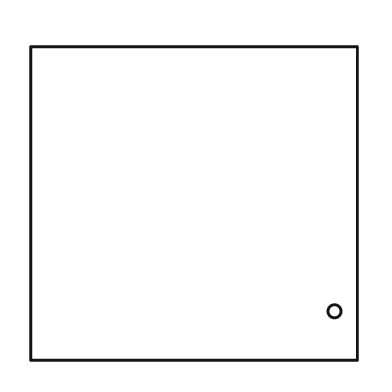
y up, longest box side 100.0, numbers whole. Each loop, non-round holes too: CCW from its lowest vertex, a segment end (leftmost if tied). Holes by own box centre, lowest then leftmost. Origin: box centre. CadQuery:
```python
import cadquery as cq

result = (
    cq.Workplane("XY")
    .moveTo(-50.0, -48.0)
    .lineTo(50.0, -48.0)
    .lineTo(50.0, 48.0)
    .lineTo(-50.0, 48.0)
    .close()
    .moveTo(43.0, -33.0)
    .circle(2.0)
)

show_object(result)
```